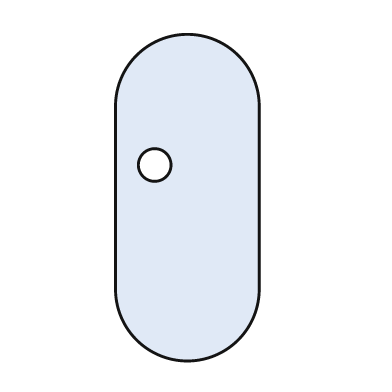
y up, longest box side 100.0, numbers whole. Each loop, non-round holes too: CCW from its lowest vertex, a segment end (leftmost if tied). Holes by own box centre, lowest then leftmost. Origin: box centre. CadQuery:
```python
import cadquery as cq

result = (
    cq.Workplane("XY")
    .moveTo(-22.0, -28.0)
    .threePointArc((0.0, -50.0), (22.0, -28.0))
    .lineTo(22.0, 28.0)
    .threePointArc((0.0, 50.0), (-22.0, 28.0))
    .close()
    .moveTo(-10.0, 10.0)
    .circle(5.0)
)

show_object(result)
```